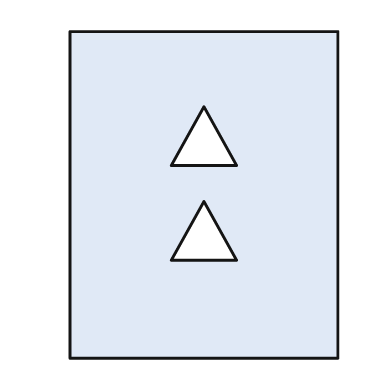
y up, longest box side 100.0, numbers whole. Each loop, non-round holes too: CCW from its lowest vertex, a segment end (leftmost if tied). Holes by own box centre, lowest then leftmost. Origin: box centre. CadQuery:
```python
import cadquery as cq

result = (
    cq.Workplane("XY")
    .moveTo(-41.0, -50.0)
    .lineTo(41.0, -50.0)
    .lineTo(41.0, 50.0)
    .lineTo(-41.0, 50.0)
    .close()
    .moveTo(-10.0, -20.0)
    .lineTo(10.0, -20.0)
    .lineTo(0.0, -2.0)
    .close()
    .moveTo(-10.0, 9.0)
    .lineTo(10.0, 9.0)
    .lineTo(0.0, 27.0)
    .close()
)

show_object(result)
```